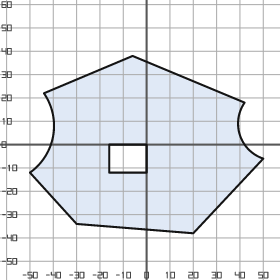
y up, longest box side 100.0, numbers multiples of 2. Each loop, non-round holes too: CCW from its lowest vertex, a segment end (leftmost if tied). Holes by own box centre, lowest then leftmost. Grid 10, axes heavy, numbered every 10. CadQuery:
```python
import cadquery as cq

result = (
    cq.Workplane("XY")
    .moveTo(20.0, -38.0)
    .lineTo(50.0, -6.0)
    .threePointArc((40.0, 4.0), (42.0, 18.0))
    .lineTo(-6.0, 38.0)
    .lineTo(-44.0, 22.0)
    .threePointArc((-40.0, 4.0), (-50.0, -12.0))
    .lineTo(-30.0, -34.0)
    .close()
    .moveTo(-16.0, -12.0)
    .lineTo(0.0, -12.0)
    .lineTo(0.0, 0.0)
    .lineTo(-16.0, 0.0)
    .close()
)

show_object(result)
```